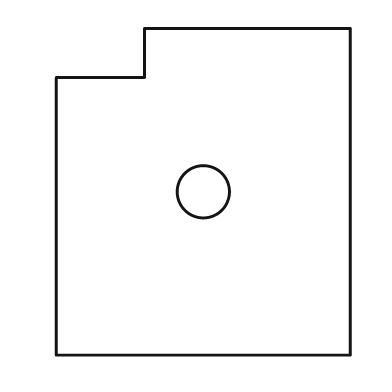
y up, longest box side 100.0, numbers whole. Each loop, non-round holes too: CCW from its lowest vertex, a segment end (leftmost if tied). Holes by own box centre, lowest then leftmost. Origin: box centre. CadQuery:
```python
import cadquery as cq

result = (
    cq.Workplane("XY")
    .moveTo(-45.0, -50.0)
    .lineTo(45.0, -50.0)
    .lineTo(45.0, 50.0)
    .lineTo(-18.0, 50.0)
    .lineTo(-18.0, 35.0)
    .lineTo(-45.0, 35.0)
    .close()
    .moveTo(0.0, 0.0)
    .circle(8.0)
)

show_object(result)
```